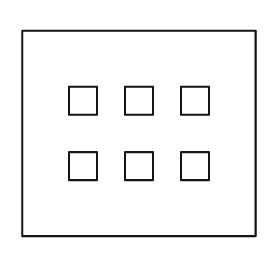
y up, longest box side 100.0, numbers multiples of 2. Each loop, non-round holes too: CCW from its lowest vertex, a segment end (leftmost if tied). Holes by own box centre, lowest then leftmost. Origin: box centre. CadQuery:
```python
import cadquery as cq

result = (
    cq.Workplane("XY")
    .moveTo(-50.0, -44.0)
    .lineTo(50.0, -44.0)
    .lineTo(50.0, 44.0)
    .lineTo(-50.0, 44.0)
    .close()
    .moveTo(-30.0, -20.0)
    .lineTo(-18.0, -20.0)
    .lineTo(-18.0, -8.0)
    .lineTo(-30.0, -8.0)
    .close()
    .moveTo(-6.0, -20.0)
    .lineTo(6.0, -20.0)
    .lineTo(6.0, -8.0)
    .lineTo(-6.0, -8.0)
    .close()
    .moveTo(18.0, -20.0)
    .lineTo(30.0, -20.0)
    .lineTo(30.0, -8.0)
    .lineTo(18.0, -8.0)
    .close()
    .moveTo(-30.0, 8.0)
    .lineTo(-18.0, 8.0)
    .lineTo(-18.0, 20.0)
    .lineTo(-30.0, 20.0)
    .close()
    .moveTo(-6.0, 8.0)
    .lineTo(6.0, 8.0)
    .lineTo(6.0, 20.0)
    .lineTo(-6.0, 20.0)
    .close()
    .moveTo(18.0, 8.0)
    .lineTo(30.0, 8.0)
    .lineTo(30.0, 20.0)
    .lineTo(18.0, 20.0)
    .close()
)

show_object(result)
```